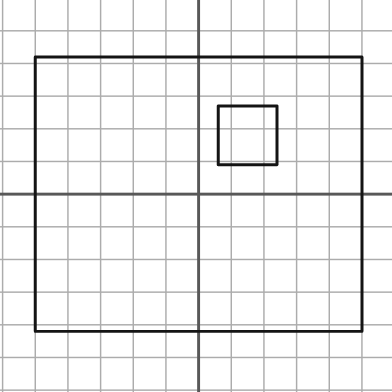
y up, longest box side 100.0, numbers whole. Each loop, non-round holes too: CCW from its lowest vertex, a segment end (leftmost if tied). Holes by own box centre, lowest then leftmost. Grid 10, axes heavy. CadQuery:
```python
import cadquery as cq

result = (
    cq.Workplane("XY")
    .moveTo(-50.0, -42.0)
    .lineTo(50.0, -42.0)
    .lineTo(50.0, 42.0)
    .lineTo(-50.0, 42.0)
    .close()
    .moveTo(6.0, 9.0)
    .lineTo(24.0, 9.0)
    .lineTo(24.0, 27.0)
    .lineTo(6.0, 27.0)
    .close()
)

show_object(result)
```